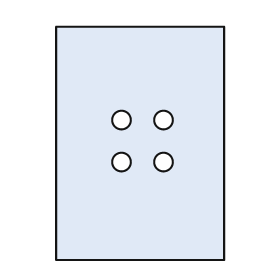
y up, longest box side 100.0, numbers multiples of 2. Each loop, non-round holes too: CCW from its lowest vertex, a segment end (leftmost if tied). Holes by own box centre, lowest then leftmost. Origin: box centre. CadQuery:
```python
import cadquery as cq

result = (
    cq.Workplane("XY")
    .moveTo(-36.0, -50.0)
    .lineTo(36.0, -50.0)
    .lineTo(36.0, 50.0)
    .lineTo(-36.0, 50.0)
    .close()
    .moveTo(-8.0, -8.0)
    .circle(4.0)
    .moveTo(10.0, -8.0)
    .circle(4.0)
    .moveTo(-8.0, 10.0)
    .circle(4.0)
    .moveTo(10.0, 10.0)
    .circle(4.0)
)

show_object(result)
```